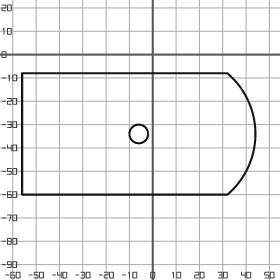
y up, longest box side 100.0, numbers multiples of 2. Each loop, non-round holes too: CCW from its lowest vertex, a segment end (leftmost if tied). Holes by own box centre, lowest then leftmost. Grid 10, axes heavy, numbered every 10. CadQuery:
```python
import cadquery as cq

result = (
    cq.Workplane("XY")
    .moveTo(-56.0, -60.0)
    .lineTo(32.0, -60.0)
    .threePointArc((44.0, -34.0), (32.0, -8.0))
    .lineTo(-56.0, -8.0)
    .close()
    .moveTo(-6.0, -34.0)
    .circle(4.0)
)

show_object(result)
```